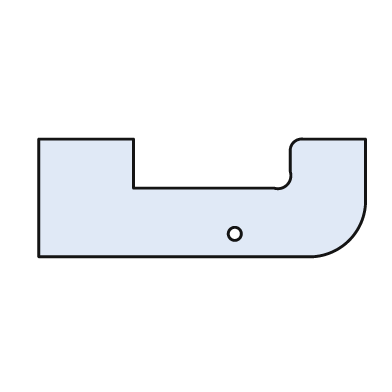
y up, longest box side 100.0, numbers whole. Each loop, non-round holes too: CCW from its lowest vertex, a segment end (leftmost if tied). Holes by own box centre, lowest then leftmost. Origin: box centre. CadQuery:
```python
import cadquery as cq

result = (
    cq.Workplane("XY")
    .moveTo(-50.0, -18.0)
    .lineTo(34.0, -18.0)
    .threePointArc((45.0, -13.0), (50.0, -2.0))
    .lineTo(50.0, 18.0)
    .lineTo(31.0, 18.0)
    .threePointArc((28.0, 17.0), (27.0, 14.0))
    .lineTo(27.0, 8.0)
    .threePointArc((26.0, 4.0), (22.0, 3.0))
    .lineTo(-21.0, 3.0)
    .lineTo(-21.0, 18.0)
    .lineTo(-50.0, 18.0)
    .close()
    .moveTo(10.0, -11.0)
    .circle(2.0)
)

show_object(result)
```